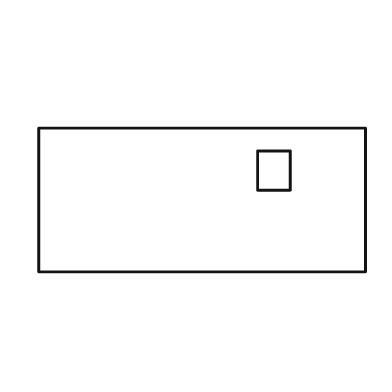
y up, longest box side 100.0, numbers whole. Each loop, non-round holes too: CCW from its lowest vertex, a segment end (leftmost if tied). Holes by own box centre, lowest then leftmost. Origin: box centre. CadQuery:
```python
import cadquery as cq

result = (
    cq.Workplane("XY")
    .moveTo(-50.0, -22.0)
    .lineTo(50.0, -22.0)
    .lineTo(50.0, 22.0)
    .lineTo(-50.0, 22.0)
    .close()
    .moveTo(17.0, 3.0)
    .lineTo(27.0, 3.0)
    .lineTo(27.0, 15.0)
    .lineTo(17.0, 15.0)
    .close()
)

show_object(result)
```